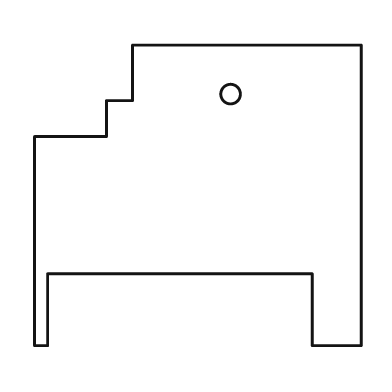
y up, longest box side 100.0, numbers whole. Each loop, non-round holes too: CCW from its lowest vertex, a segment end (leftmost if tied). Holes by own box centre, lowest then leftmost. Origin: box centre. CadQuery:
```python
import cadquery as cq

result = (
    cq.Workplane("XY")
    .moveTo(-50.0, -46.0)
    .lineTo(-46.0, -46.0)
    .lineTo(-46.0, -24.0)
    .lineTo(35.0, -24.0)
    .lineTo(35.0, -46.0)
    .lineTo(50.0, -46.0)
    .lineTo(50.0, 46.0)
    .lineTo(-20.0, 46.0)
    .lineTo(-20.0, 29.0)
    .lineTo(-28.0, 29.0)
    .lineTo(-28.0, 18.0)
    .lineTo(-50.0, 18.0)
    .close()
    .moveTo(10.0, 31.0)
    .circle(3.0)
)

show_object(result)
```